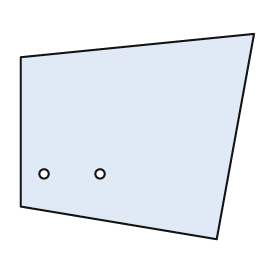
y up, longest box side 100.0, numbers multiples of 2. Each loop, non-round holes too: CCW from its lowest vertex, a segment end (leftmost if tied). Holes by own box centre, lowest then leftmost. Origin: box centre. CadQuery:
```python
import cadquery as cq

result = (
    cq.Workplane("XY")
    .moveTo(34.0, -44.0)
    .lineTo(50.0, 44.0)
    .lineTo(-50.0, 34.0)
    .lineTo(-50.0, -30.0)
    .close()
    .moveTo(-40.0, -16.0)
    .circle(2.0)
    .moveTo(-16.0, -16.0)
    .circle(2.0)
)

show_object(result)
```